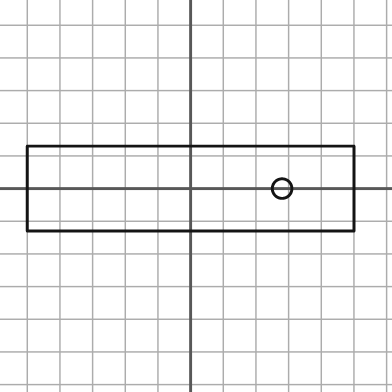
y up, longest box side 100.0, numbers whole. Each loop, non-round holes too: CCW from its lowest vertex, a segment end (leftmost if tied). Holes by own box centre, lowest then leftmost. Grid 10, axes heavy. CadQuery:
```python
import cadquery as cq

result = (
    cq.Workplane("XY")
    .moveTo(-50.0, -13.0)
    .lineTo(50.0, -13.0)
    .lineTo(50.0, 13.0)
    .lineTo(-50.0, 13.0)
    .close()
    .moveTo(28.0, 0.0)
    .circle(3.0)
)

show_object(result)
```